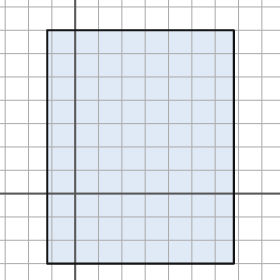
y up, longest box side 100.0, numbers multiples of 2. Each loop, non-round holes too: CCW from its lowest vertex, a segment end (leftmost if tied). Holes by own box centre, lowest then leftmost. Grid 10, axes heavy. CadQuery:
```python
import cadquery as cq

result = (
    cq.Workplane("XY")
    .moveTo(-12.0, -30.0)
    .lineTo(68.0, -30.0)
    .lineTo(68.0, 70.0)
    .lineTo(-12.0, 70.0)
    .close()
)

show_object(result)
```